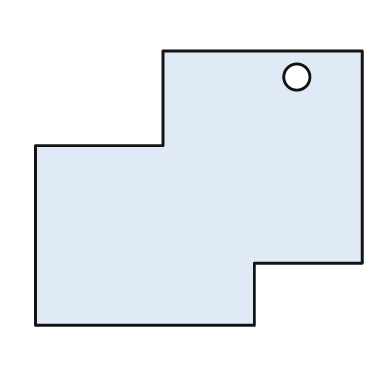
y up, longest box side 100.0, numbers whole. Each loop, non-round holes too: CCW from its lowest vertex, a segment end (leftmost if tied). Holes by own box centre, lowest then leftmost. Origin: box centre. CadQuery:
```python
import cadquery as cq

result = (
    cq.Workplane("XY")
    .moveTo(-50.0, -42.0)
    .lineTo(17.0, -42.0)
    .lineTo(17.0, -23.0)
    .lineTo(50.0, -23.0)
    .lineTo(50.0, 42.0)
    .lineTo(-11.0, 42.0)
    .lineTo(-11.0, 13.0)
    .lineTo(-50.0, 13.0)
    .close()
    .moveTo(30.0, 34.0)
    .circle(4.0)
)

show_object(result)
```